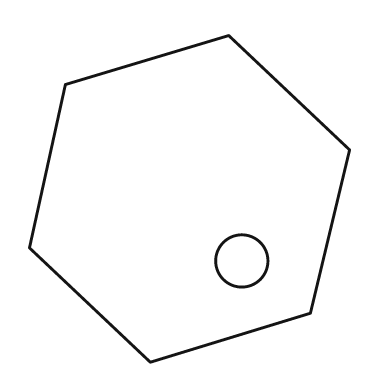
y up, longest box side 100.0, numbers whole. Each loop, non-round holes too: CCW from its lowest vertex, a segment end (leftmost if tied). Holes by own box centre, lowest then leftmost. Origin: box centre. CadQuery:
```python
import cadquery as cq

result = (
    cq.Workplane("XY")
    .moveTo(-12.0, -50.0)
    .lineTo(37.0, -35.0)
    .lineTo(49.0, 15.0)
    .lineTo(12.0, 50.0)
    .lineTo(-38.0, 35.0)
    .lineTo(-49.0, -15.0)
    .close()
    .moveTo(16.0, -19.0)
    .circle(8.0)
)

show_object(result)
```